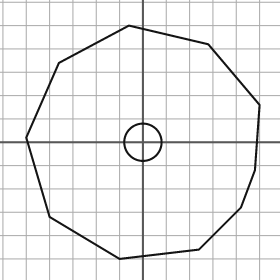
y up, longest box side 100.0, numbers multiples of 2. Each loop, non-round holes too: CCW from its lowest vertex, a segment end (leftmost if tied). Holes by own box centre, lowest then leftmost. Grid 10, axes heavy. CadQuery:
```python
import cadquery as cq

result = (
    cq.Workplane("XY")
    .moveTo(-10.0, -50.0)
    .lineTo(24.0, -46.0)
    .lineTo(42.0, -28.0)
    .lineTo(48.0, -12.0)
    .lineTo(50.0, 16.0)
    .lineTo(28.0, 42.0)
    .lineTo(-6.0, 50.0)
    .lineTo(-36.0, 34.0)
    .lineTo(-50.0, 2.0)
    .lineTo(-40.0, -32.0)
    .close()
    .moveTo(0.0, 0.0)
    .circle(8.0)
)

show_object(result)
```